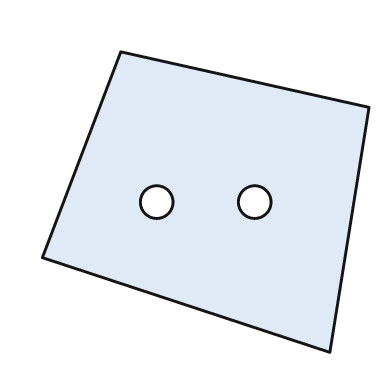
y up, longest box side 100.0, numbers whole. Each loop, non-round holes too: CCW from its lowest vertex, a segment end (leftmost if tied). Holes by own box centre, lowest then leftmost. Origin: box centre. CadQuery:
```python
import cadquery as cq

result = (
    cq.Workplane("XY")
    .moveTo(38.0, -46.0)
    .lineTo(50.0, 29.0)
    .lineTo(-26.0, 46.0)
    .lineTo(-50.0, -17.0)
    .close()
    .moveTo(-15.0, 0.0)
    .circle(5.0)
    .moveTo(15.0, 0.0)
    .circle(5.0)
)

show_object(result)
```